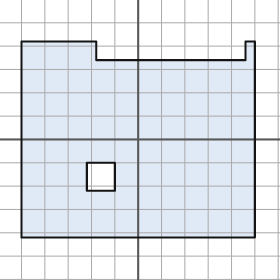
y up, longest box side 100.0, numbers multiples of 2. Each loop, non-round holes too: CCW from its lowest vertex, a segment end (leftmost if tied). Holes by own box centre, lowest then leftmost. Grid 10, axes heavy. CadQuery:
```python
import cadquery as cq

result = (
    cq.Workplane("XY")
    .moveTo(-50.0, -42.0)
    .lineTo(50.0, -42.0)
    .lineTo(50.0, 42.0)
    .lineTo(46.0, 42.0)
    .lineTo(46.0, 34.0)
    .lineTo(-18.0, 34.0)
    .lineTo(-18.0, 42.0)
    .lineTo(-50.0, 42.0)
    .close()
    .moveTo(-22.0, -22.0)
    .lineTo(-10.0, -22.0)
    .lineTo(-10.0, -10.0)
    .lineTo(-22.0, -10.0)
    .close()
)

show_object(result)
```